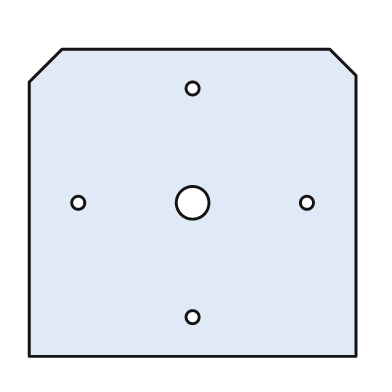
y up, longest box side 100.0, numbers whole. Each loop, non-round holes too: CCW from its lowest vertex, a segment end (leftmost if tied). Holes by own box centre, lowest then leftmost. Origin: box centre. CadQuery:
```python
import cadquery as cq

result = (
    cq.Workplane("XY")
    .moveTo(-50.0, -47.0)
    .lineTo(50.0, -47.0)
    .lineTo(50.0, 39.0)
    .lineTo(42.0, 47.0)
    .lineTo(-40.0, 47.0)
    .lineTo(-50.0, 37.0)
    .close()
    .moveTo(0.0, -35.0)
    .circle(2.0)
    .moveTo(-35.0, 0.0)
    .circle(2.0)
    .moveTo(0.0, 0.0)
    .circle(5.0)
    .moveTo(35.0, 0.0)
    .circle(2.0)
    .moveTo(0.0, 35.0)
    .circle(2.0)
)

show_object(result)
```